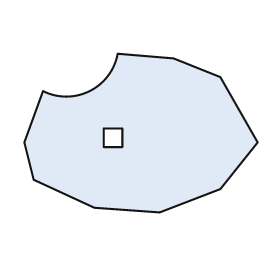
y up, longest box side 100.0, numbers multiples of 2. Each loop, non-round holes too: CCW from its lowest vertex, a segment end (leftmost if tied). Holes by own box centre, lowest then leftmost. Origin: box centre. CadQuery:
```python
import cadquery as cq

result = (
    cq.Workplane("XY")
    .moveTo(8.0, -34.0)
    .lineTo(34.0, -24.0)
    .lineTo(50.0, -4.0)
    .lineTo(34.0, 24.0)
    .lineTo(14.0, 32.0)
    .lineTo(-10.0, 34.0)
    .threePointArc((-22.0, 18.0), (-42.0, 18.0))
    .lineTo(-50.0, -4.0)
    .lineTo(-46.0, -20.0)
    .lineTo(-20.0, -32.0)
    .close()
    .moveTo(-16.0, -6.0)
    .lineTo(-8.0, -6.0)
    .lineTo(-8.0, 2.0)
    .lineTo(-16.0, 2.0)
    .close()
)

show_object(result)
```